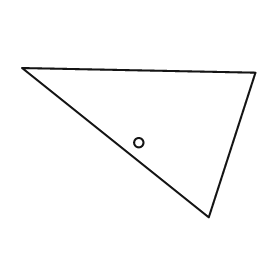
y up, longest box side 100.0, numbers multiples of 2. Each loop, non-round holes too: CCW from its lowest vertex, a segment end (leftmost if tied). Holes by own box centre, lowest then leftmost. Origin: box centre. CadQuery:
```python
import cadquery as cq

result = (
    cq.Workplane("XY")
    .moveTo(30.0, -32.0)
    .lineTo(50.0, 30.0)
    .lineTo(-50.0, 32.0)
    .close()
    .moveTo(0.0, 0.0)
    .circle(2.0)
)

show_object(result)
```